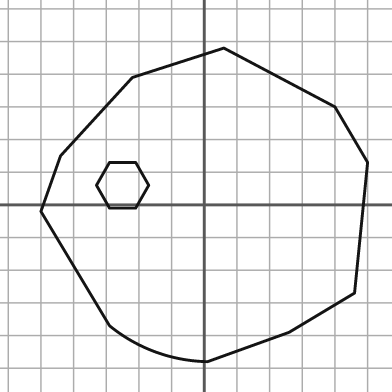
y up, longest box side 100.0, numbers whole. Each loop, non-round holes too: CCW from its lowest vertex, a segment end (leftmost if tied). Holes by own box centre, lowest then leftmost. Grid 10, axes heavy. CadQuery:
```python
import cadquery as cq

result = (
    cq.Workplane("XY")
    .moveTo(1.0, -48.0)
    .lineTo(26.0, -39.0)
    .lineTo(46.0, -27.0)
    .lineTo(50.0, 13.0)
    .lineTo(40.0, 30.0)
    .lineTo(6.0, 48.0)
    .lineTo(-22.0, 39.0)
    .lineTo(-44.0, 15.0)
    .lineTo(-50.0, -2.0)
    .lineTo(-29.0, -37.0)
    .threePointArc((-15.0, -45.0), (1.0, -48.0))
    .close()
    .moveTo(-29.0, -1.0)
    .lineTo(-21.0, -1.0)
    .lineTo(-17.0, 6.0)
    .lineTo(-21.0, 13.0)
    .lineTo(-29.0, 13.0)
    .lineTo(-33.0, 6.0)
    .close()
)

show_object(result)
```